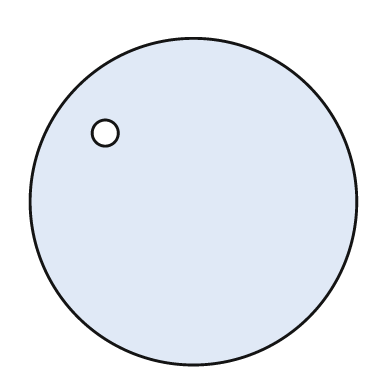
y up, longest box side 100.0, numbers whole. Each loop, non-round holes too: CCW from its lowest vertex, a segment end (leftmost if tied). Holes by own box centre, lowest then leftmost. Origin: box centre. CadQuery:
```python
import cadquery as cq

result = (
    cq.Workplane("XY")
    .moveTo(0.0, 0.0)
    .circle(50.0)
    .moveTo(-27.0, 21.0)
    .circle(4.0)
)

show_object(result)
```